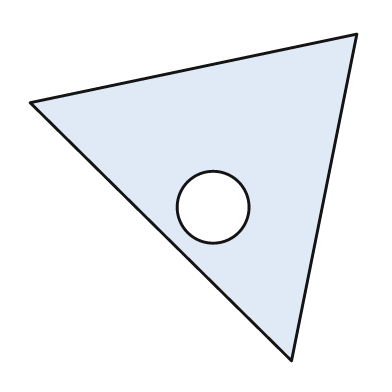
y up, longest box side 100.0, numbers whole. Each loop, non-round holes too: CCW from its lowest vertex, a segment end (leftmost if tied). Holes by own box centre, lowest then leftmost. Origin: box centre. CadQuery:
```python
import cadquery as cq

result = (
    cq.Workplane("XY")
    .moveTo(30.0, -50.0)
    .lineTo(50.0, 50.0)
    .lineTo(-50.0, 29.0)
    .close()
    .moveTo(6.0, -3.0)
    .circle(11.0)
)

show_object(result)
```